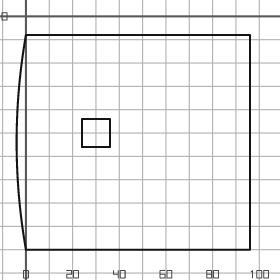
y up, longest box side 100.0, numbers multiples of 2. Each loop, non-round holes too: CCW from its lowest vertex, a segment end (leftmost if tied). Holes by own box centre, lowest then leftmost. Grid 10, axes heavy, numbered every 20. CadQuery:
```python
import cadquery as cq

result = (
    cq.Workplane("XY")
    .moveTo(0.0, -100.0)
    .lineTo(96.0, -100.0)
    .lineTo(96.0, -8.0)
    .lineTo(0.0, -8.0)
    .threePointArc((-4.0, -54.0), (0.0, -100.0))
    .close()
    .moveTo(24.0, -56.0)
    .lineTo(36.0, -56.0)
    .lineTo(36.0, -44.0)
    .lineTo(24.0, -44.0)
    .close()
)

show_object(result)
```